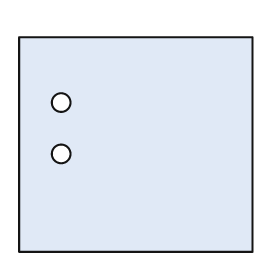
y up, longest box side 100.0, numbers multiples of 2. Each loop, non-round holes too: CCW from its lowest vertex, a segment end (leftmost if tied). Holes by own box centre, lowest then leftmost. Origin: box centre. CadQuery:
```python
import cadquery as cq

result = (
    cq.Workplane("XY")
    .moveTo(-50.0, -46.0)
    .lineTo(50.0, -46.0)
    .lineTo(50.0, 46.0)
    .lineTo(-50.0, 46.0)
    .close()
    .moveTo(-32.0, -4.0)
    .circle(4.0)
    .moveTo(-32.0, 18.0)
    .circle(4.0)
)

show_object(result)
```